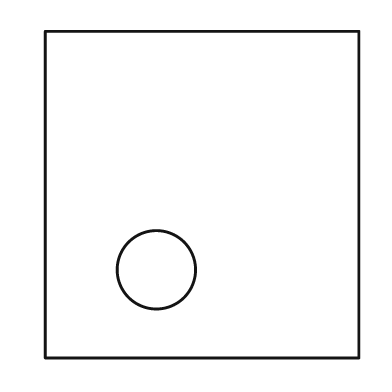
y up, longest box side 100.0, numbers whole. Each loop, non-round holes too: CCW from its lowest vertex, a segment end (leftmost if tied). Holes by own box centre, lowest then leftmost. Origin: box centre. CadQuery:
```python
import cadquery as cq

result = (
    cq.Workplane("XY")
    .moveTo(-48.0, -50.0)
    .lineTo(48.0, -50.0)
    .lineTo(48.0, 50.0)
    .lineTo(-48.0, 50.0)
    .close()
    .moveTo(-14.0, -23.0)
    .circle(12.0)
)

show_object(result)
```